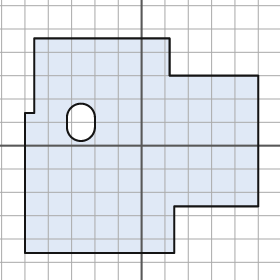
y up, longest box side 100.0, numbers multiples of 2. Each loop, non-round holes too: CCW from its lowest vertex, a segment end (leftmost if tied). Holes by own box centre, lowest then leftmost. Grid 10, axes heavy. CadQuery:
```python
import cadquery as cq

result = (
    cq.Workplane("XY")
    .moveTo(-50.0, -46.0)
    .lineTo(14.0, -46.0)
    .lineTo(14.0, -26.0)
    .lineTo(50.0, -26.0)
    .lineTo(50.0, 30.0)
    .lineTo(12.0, 30.0)
    .lineTo(12.0, 46.0)
    .lineTo(-46.0, 46.0)
    .lineTo(-46.0, 14.0)
    .lineTo(-50.0, 14.0)
    .close()
    .moveTo(-32.0, 8.0)
    .threePointArc((-26.0, 2.0), (-20.0, 8.0))
    .lineTo(-20.0, 12.0)
    .threePointArc((-26.0, 18.0), (-32.0, 12.0))
    .close()
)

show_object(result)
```